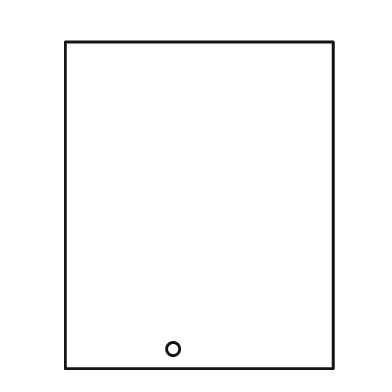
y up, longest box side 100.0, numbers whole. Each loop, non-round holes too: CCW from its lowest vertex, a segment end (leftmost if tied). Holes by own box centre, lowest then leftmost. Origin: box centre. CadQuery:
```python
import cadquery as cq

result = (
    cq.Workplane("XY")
    .moveTo(-41.0, -50.0)
    .lineTo(41.0, -50.0)
    .lineTo(41.0, 50.0)
    .lineTo(-41.0, 50.0)
    .close()
    .moveTo(-8.0, -44.0)
    .circle(2.0)
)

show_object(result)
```